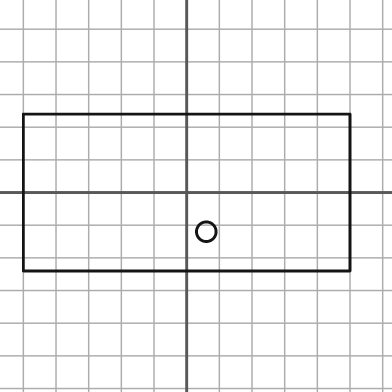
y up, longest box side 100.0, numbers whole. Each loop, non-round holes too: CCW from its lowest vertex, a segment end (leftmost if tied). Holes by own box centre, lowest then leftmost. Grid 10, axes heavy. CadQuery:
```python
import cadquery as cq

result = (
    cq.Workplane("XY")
    .moveTo(-50.0, -24.0)
    .lineTo(50.0, -24.0)
    .lineTo(50.0, 24.0)
    .lineTo(-50.0, 24.0)
    .close()
    .moveTo(6.0, -12.0)
    .circle(3.0)
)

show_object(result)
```